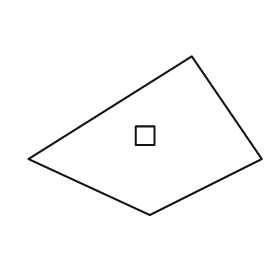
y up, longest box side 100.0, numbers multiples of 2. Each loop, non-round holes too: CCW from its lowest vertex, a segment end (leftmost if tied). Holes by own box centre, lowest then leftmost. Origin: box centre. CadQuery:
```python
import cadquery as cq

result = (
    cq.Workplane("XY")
    .moveTo(2.0, -34.0)
    .lineTo(50.0, -10.0)
    .lineTo(20.0, 34.0)
    .lineTo(-50.0, -10.0)
    .close()
    .moveTo(-4.0, -4.0)
    .lineTo(4.0, -4.0)
    .lineTo(4.0, 4.0)
    .lineTo(-4.0, 4.0)
    .close()
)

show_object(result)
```